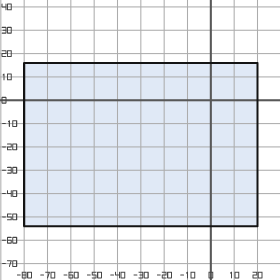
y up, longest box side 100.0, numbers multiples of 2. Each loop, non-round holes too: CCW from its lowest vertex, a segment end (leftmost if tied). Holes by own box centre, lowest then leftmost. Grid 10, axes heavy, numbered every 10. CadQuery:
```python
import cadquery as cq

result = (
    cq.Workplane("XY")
    .moveTo(-80.0, -54.0)
    .lineTo(20.0, -54.0)
    .lineTo(20.0, 16.0)
    .lineTo(-80.0, 16.0)
    .close()
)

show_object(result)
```